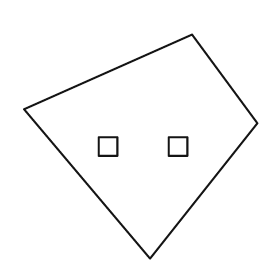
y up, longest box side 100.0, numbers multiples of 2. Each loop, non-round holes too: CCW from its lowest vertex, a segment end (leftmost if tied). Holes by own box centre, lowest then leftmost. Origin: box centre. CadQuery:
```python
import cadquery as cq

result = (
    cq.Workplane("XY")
    .moveTo(4.0, -48.0)
    .lineTo(50.0, 10.0)
    .lineTo(22.0, 48.0)
    .lineTo(-50.0, 16.0)
    .close()
    .moveTo(-18.0, -4.0)
    .lineTo(-10.0, -4.0)
    .lineTo(-10.0, 4.0)
    .lineTo(-18.0, 4.0)
    .close()
    .moveTo(12.0, -4.0)
    .lineTo(20.0, -4.0)
    .lineTo(20.0, 4.0)
    .lineTo(12.0, 4.0)
    .close()
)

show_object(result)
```